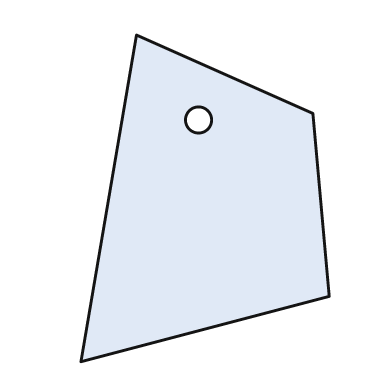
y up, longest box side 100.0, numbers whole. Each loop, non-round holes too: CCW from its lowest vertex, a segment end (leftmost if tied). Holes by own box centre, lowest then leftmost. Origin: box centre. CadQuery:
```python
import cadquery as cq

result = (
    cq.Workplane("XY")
    .moveTo(-38.0, -50.0)
    .lineTo(38.0, -30.0)
    .lineTo(33.0, 26.0)
    .lineTo(-21.0, 50.0)
    .close()
    .moveTo(-2.0, 24.0)
    .circle(4.0)
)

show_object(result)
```